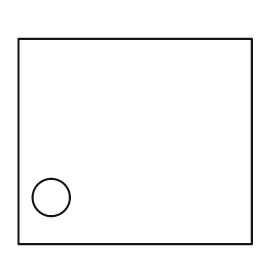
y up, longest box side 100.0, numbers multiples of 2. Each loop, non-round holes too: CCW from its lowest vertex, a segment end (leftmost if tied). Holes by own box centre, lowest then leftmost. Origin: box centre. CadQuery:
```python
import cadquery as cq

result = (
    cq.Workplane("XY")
    .moveTo(-50.0, -44.0)
    .lineTo(50.0, -44.0)
    .lineTo(50.0, 44.0)
    .lineTo(-50.0, 44.0)
    .close()
    .moveTo(-36.0, -24.0)
    .circle(8.0)
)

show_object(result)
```